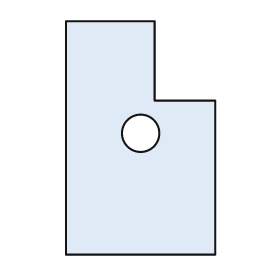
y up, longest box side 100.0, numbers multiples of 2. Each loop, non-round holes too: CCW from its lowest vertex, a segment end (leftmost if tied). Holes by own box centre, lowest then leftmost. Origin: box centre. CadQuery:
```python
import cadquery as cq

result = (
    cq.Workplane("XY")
    .moveTo(-32.0, -50.0)
    .lineTo(32.0, -50.0)
    .lineTo(32.0, 16.0)
    .lineTo(6.0, 16.0)
    .lineTo(6.0, 50.0)
    .lineTo(-32.0, 50.0)
    .close()
    .moveTo(0.0, 2.0)
    .circle(8.0)
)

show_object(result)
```